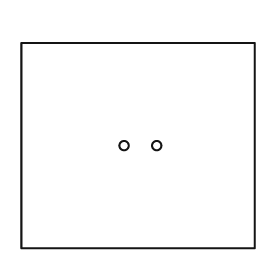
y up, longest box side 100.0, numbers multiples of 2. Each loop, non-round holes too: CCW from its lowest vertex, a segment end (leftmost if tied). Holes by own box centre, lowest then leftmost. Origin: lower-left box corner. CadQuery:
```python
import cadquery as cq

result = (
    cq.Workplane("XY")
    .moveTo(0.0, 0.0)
    .lineTo(100.0, 0.0)
    .lineTo(100.0, 88.0)
    .lineTo(0.0, 88.0)
    .close()
    .moveTo(44.0, 44.0)
    .circle(2.0)
    .moveTo(58.0, 44.0)
    .circle(2.0)
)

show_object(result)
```